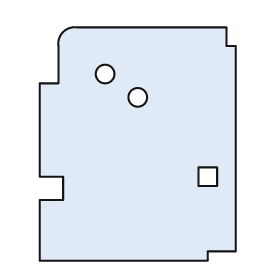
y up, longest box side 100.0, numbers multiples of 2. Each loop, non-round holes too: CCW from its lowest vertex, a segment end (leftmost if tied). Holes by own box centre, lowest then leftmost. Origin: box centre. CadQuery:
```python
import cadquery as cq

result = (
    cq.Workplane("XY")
    .moveTo(-42.0, -50.0)
    .lineTo(30.0, -50.0)
    .lineTo(30.0, -46.0)
    .lineTo(42.0, -46.0)
    .lineTo(42.0, 42.0)
    .lineTo(38.0, 42.0)
    .lineTo(38.0, 50.0)
    .lineTo(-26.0, 50.0)
    .threePointArc((-32.0, 48.0), (-34.0, 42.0))
    .lineTo(-34.0, 26.0)
    .lineTo(-42.0, 26.0)
    .lineTo(-42.0, -14.0)
    .lineTo(-32.0, -14.0)
    .lineTo(-32.0, -24.0)
    .lineTo(-42.0, -24.0)
    .close()
    .moveTo(26.0, -18.0)
    .lineTo(34.0, -18.0)
    .lineTo(34.0, -10.0)
    .lineTo(26.0, -10.0)
    .close()
    .moveTo(0.0, 20.0)
    .circle(4.0)
    .moveTo(-14.0, 30.0)
    .circle(4.0)
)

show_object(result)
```